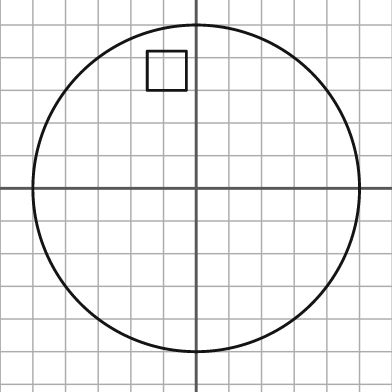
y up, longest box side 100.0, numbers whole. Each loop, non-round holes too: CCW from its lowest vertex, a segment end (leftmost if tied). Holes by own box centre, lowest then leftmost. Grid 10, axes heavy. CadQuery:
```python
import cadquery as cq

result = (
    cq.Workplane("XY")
    .moveTo(0.0, 0.0)
    .circle(50.0)
    .moveTo(-15.0, 30.0)
    .lineTo(-3.0, 30.0)
    .lineTo(-3.0, 42.0)
    .lineTo(-15.0, 42.0)
    .close()
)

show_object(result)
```